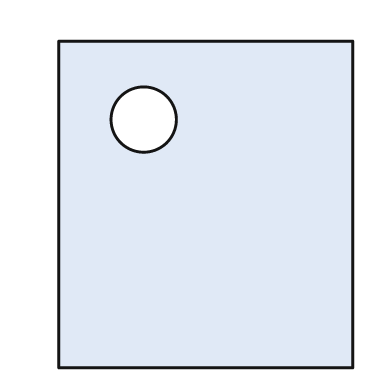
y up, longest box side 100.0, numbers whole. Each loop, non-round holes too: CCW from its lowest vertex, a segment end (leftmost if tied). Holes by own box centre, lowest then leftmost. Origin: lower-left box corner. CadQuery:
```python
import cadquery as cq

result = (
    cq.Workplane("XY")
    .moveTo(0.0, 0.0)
    .lineTo(90.0, 0.0)
    .lineTo(90.0, 100.0)
    .lineTo(0.0, 100.0)
    .close()
    .moveTo(26.0, 76.0)
    .circle(10.0)
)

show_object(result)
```